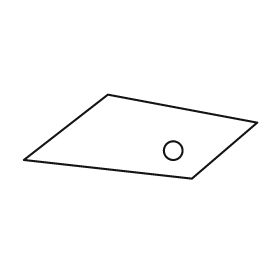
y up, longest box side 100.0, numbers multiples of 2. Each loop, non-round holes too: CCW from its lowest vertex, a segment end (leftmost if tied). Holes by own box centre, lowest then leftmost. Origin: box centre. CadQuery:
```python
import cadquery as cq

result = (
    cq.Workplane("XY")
    .moveTo(22.0, -18.0)
    .lineTo(50.0, 6.0)
    .lineTo(-14.0, 18.0)
    .lineTo(-50.0, -10.0)
    .close()
    .moveTo(14.0, -6.0)
    .circle(4.0)
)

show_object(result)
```